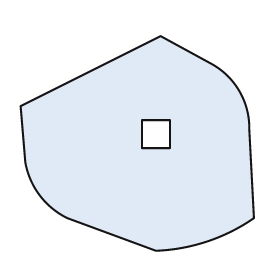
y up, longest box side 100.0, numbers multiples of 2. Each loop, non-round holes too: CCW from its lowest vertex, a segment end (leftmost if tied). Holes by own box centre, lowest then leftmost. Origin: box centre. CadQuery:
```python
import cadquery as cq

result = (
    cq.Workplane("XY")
    .moveTo(8.0, -46.0)
    .threePointArc((30.0, -42.0), (50.0, -32.0))
    .lineTo(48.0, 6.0)
    .threePointArc((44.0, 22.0), (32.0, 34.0))
    .lineTo(10.0, 46.0)
    .lineTo(-50.0, 16.0)
    .lineTo(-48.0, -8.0)
    .threePointArc((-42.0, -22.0), (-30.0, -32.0))
    .close()
    .moveTo(2.0, -2.0)
    .lineTo(14.0, -2.0)
    .lineTo(14.0, 10.0)
    .lineTo(2.0, 10.0)
    .close()
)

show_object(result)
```